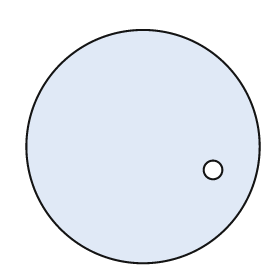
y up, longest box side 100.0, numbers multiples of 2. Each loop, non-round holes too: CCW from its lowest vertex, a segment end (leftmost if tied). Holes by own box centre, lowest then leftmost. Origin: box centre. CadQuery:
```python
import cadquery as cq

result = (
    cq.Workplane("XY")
    .moveTo(0.0, 0.0)
    .circle(50.0)
    .moveTo(30.0, -10.0)
    .circle(4.0)
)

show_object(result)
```